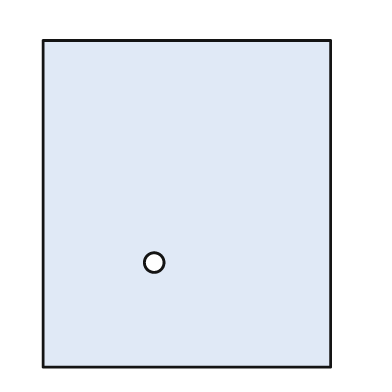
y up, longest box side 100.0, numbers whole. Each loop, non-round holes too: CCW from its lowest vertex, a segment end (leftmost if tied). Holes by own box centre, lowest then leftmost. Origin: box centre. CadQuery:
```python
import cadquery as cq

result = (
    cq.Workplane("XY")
    .moveTo(-44.0, -50.0)
    .lineTo(44.0, -50.0)
    .lineTo(44.0, 50.0)
    .lineTo(-44.0, 50.0)
    .close()
    .moveTo(-10.0, -18.0)
    .circle(3.0)
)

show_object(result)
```